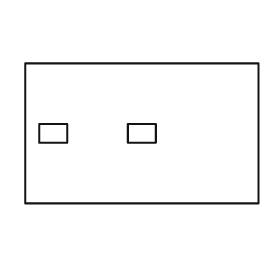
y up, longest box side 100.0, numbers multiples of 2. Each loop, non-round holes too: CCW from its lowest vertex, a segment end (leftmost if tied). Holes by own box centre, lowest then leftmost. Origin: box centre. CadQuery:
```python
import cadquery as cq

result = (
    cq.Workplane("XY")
    .moveTo(-50.0, -30.0)
    .lineTo(50.0, -30.0)
    .lineTo(50.0, 30.0)
    .lineTo(-50.0, 30.0)
    .close()
    .moveTo(-44.0, -4.0)
    .lineTo(-32.0, -4.0)
    .lineTo(-32.0, 4.0)
    .lineTo(-44.0, 4.0)
    .close()
    .moveTo(-6.0, -4.0)
    .lineTo(6.0, -4.0)
    .lineTo(6.0, 4.0)
    .lineTo(-6.0, 4.0)
    .close()
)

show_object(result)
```